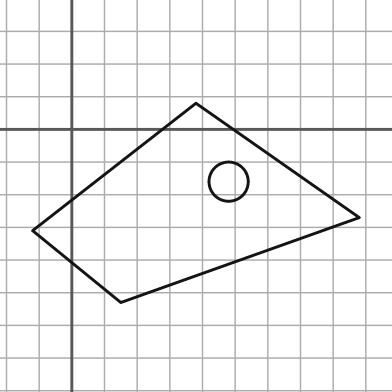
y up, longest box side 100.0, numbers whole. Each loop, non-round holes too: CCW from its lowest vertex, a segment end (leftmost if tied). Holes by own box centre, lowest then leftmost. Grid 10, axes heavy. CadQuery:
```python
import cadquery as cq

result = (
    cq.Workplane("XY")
    .moveTo(15.0, -53.0)
    .lineTo(88.0, -27.0)
    .lineTo(38.0, 8.0)
    .lineTo(-12.0, -31.0)
    .close()
    .moveTo(48.0, -16.0)
    .circle(6.0)
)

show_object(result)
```